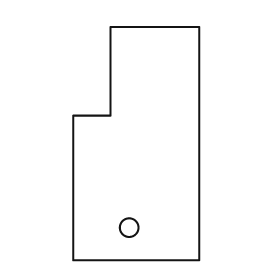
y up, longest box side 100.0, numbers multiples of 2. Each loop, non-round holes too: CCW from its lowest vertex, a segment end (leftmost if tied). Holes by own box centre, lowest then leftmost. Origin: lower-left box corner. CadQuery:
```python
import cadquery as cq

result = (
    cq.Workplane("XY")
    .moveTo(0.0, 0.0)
    .lineTo(54.0, 0.0)
    .lineTo(54.0, 100.0)
    .lineTo(16.0, 100.0)
    .lineTo(16.0, 62.0)
    .lineTo(0.0, 62.0)
    .close()
    .moveTo(24.0, 14.0)
    .circle(4.0)
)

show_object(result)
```